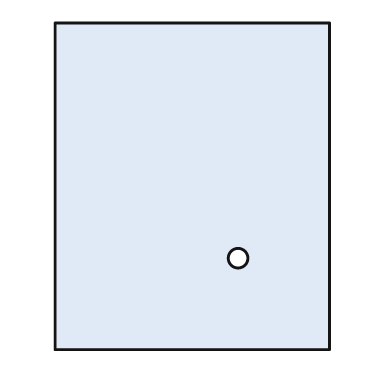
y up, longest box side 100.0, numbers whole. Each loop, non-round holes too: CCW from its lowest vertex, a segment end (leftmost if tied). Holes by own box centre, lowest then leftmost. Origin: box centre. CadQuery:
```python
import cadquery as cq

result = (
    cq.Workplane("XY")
    .moveTo(-42.0, -50.0)
    .lineTo(42.0, -50.0)
    .lineTo(42.0, 50.0)
    .lineTo(-42.0, 50.0)
    .close()
    .moveTo(14.0, -22.0)
    .circle(3.0)
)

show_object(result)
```